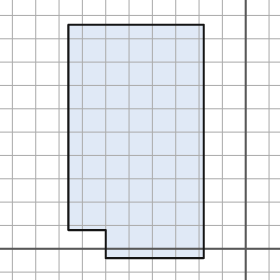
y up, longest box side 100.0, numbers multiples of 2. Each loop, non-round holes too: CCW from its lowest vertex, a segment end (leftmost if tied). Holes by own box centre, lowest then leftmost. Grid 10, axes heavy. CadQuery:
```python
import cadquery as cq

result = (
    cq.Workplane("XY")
    .moveTo(-60.0, -4.0)
    .lineTo(-18.0, -4.0)
    .lineTo(-18.0, 96.0)
    .lineTo(-76.0, 96.0)
    .lineTo(-76.0, 8.0)
    .lineTo(-60.0, 8.0)
    .close()
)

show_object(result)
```